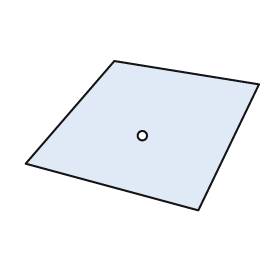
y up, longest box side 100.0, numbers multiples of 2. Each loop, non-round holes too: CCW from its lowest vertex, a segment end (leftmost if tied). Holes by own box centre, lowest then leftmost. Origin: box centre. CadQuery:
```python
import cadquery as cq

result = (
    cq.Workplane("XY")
    .moveTo(24.0, -32.0)
    .lineTo(50.0, 22.0)
    .lineTo(-12.0, 32.0)
    .lineTo(-50.0, -12.0)
    .close()
    .moveTo(0.0, 0.0)
    .circle(2.0)
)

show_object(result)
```